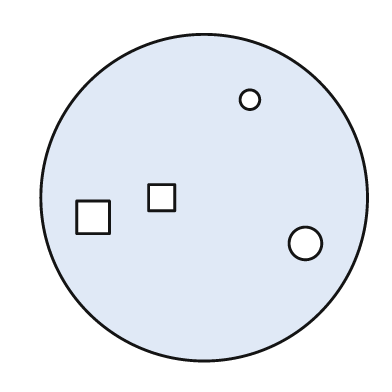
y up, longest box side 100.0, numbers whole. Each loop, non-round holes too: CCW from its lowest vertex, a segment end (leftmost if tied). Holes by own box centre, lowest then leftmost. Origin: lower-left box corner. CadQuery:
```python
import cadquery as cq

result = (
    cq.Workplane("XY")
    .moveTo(50.0, 50.0)
    .circle(50.0)
    .moveTo(81.0, 36.0)
    .circle(5.0)
    .moveTo(11.0, 39.0)
    .lineTo(21.0, 39.0)
    .lineTo(21.0, 49.0)
    .lineTo(11.0, 49.0)
    .close()
    .moveTo(33.0, 46.0)
    .lineTo(41.0, 46.0)
    .lineTo(41.0, 54.0)
    .lineTo(33.0, 54.0)
    .close()
    .moveTo(64.0, 80.0)
    .circle(3.0)
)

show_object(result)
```